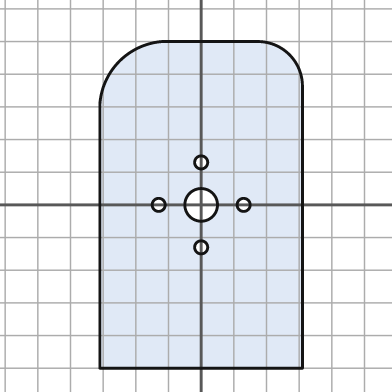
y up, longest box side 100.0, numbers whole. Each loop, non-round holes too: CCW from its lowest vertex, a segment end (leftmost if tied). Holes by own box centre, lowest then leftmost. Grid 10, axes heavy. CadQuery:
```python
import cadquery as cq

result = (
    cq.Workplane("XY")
    .moveTo(-31.0, -50.0)
    .lineTo(31.0, -50.0)
    .lineTo(31.0, 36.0)
    .threePointArc((27.0, 46.0), (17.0, 50.0))
    .lineTo(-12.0, 50.0)
    .threePointArc((-25.0, 44.0), (-31.0, 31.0))
    .close()
    .moveTo(0.0, -13.0)
    .circle(2.0)
    .moveTo(-13.0, 0.0)
    .circle(2.0)
    .moveTo(0.0, 0.0)
    .circle(5.0)
    .moveTo(13.0, 0.0)
    .circle(2.0)
    .moveTo(0.0, 13.0)
    .circle(2.0)
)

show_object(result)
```